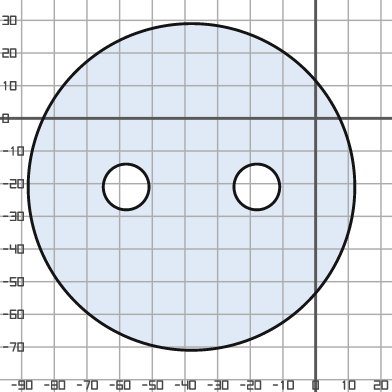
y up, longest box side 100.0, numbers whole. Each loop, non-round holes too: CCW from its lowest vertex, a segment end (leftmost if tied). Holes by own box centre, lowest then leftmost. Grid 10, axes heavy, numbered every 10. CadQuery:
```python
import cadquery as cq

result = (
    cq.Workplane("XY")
    .moveTo(-38.0, -21.0)
    .circle(50.0)
    .moveTo(-58.0, -21.0)
    .circle(7.0)
    .moveTo(-18.0, -21.0)
    .circle(7.0)
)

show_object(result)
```